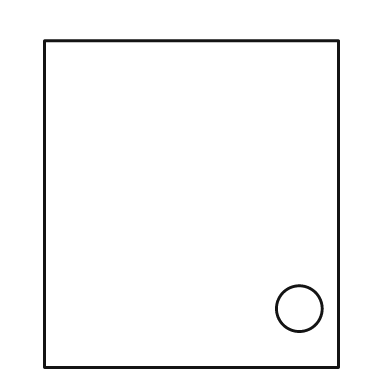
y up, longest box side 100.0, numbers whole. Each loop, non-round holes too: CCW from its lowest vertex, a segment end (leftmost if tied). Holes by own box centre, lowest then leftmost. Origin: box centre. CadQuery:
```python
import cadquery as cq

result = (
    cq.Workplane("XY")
    .moveTo(-45.0, -50.0)
    .lineTo(45.0, -50.0)
    .lineTo(45.0, 50.0)
    .lineTo(-45.0, 50.0)
    .close()
    .moveTo(33.0, -32.0)
    .circle(7.0)
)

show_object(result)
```